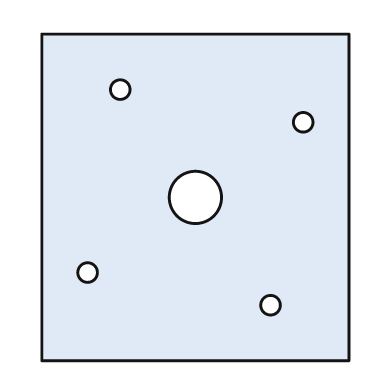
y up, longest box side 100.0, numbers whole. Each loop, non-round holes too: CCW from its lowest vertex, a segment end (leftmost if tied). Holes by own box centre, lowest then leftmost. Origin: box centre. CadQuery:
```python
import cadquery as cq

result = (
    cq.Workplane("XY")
    .moveTo(-47.0, -50.0)
    .lineTo(47.0, -50.0)
    .lineTo(47.0, 50.0)
    .lineTo(-47.0, 50.0)
    .close()
    .moveTo(23.0, -33.0)
    .circle(3.0)
    .moveTo(-33.0, -23.0)
    .circle(3.0)
    .moveTo(0.0, 0.0)
    .circle(8.0)
    .moveTo(33.0, 23.0)
    .circle(3.0)
    .moveTo(-23.0, 33.0)
    .circle(3.0)
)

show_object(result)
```